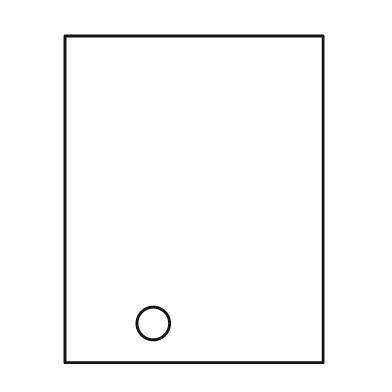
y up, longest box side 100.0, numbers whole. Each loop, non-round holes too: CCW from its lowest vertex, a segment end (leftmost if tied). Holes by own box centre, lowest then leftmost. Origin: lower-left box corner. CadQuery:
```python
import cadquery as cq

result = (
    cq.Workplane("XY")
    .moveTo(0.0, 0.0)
    .lineTo(79.0, 0.0)
    .lineTo(79.0, 100.0)
    .lineTo(0.0, 100.0)
    .close()
    .moveTo(27.0, 12.0)
    .circle(5.0)
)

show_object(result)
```